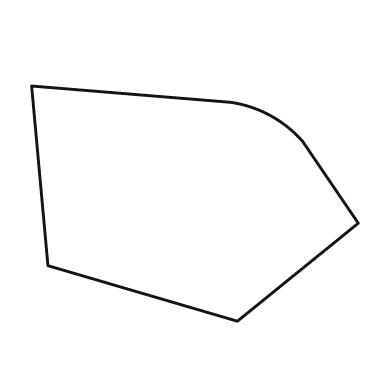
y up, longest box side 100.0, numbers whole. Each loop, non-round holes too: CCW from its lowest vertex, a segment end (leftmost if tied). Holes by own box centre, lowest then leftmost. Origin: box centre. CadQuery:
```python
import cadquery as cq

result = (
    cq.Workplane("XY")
    .moveTo(13.0, -36.0)
    .lineTo(50.0, -6.0)
    .lineTo(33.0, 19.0)
    .threePointArc((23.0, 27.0), (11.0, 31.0))
    .lineTo(-50.0, 36.0)
    .lineTo(-45.0, -19.0)
    .close()
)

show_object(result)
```